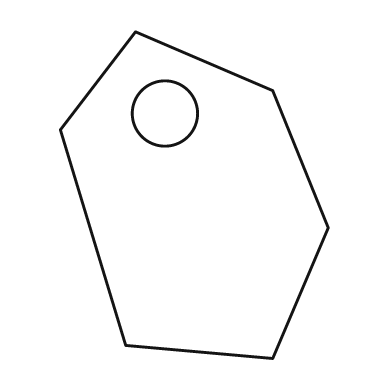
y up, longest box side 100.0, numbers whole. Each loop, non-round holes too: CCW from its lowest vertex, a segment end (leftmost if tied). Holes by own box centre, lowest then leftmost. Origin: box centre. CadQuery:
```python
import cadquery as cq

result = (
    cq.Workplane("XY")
    .moveTo(24.0, -50.0)
    .lineTo(41.0, -10.0)
    .lineTo(24.0, 32.0)
    .lineTo(-18.0, 50.0)
    .lineTo(-41.0, 20.0)
    .lineTo(-21.0, -46.0)
    .close()
    .moveTo(-9.0, 25.0)
    .circle(10.0)
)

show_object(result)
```